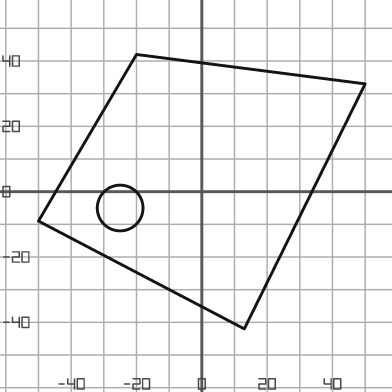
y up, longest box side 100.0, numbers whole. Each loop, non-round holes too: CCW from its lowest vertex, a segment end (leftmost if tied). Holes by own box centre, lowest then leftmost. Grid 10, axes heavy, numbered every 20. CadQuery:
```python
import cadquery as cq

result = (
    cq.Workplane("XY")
    .moveTo(13.0, -42.0)
    .lineTo(50.0, 33.0)
    .lineTo(-20.0, 42.0)
    .lineTo(-50.0, -9.0)
    .close()
    .moveTo(-25.0, -5.0)
    .circle(7.0)
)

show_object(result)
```